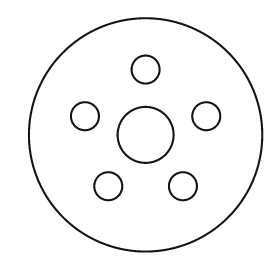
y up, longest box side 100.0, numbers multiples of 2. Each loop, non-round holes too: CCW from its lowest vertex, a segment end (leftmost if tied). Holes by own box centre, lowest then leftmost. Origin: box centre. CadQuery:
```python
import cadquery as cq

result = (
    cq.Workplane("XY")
    .moveTo(0.0, 0.0)
    .circle(50.0)
    .moveTo(-16.0, -22.0)
    .circle(6.0)
    .moveTo(16.0, -22.0)
    .circle(6.0)
    .moveTo(0.0, 0.0)
    .circle(12.0)
    .moveTo(-26.0, 8.0)
    .circle(6.0)
    .moveTo(26.0, 8.0)
    .circle(6.0)
    .moveTo(0.0, 28.0)
    .circle(6.0)
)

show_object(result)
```